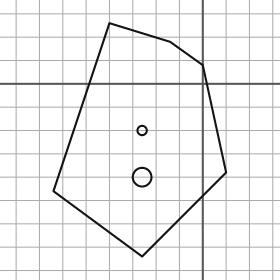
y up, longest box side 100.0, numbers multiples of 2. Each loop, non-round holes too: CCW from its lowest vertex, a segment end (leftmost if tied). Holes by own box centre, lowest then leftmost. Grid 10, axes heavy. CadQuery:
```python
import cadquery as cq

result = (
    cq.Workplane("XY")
    .moveTo(-26.0, -74.0)
    .lineTo(10.0, -38.0)
    .lineTo(0.0, 8.0)
    .lineTo(-14.0, 18.0)
    .lineTo(-40.0, 26.0)
    .lineTo(-64.0, -46.0)
    .close()
    .moveTo(-26.0, -40.0)
    .circle(4.0)
    .moveTo(-26.0, -20.0)
    .circle(2.0)
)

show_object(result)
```